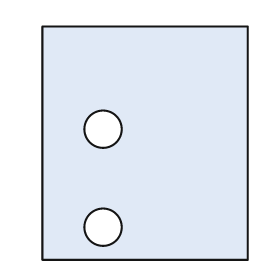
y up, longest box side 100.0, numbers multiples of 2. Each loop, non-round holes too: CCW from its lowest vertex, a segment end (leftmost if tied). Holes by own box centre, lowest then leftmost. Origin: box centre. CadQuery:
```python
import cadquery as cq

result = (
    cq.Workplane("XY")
    .moveTo(-44.0, -50.0)
    .lineTo(44.0, -50.0)
    .lineTo(44.0, 50.0)
    .lineTo(-44.0, 50.0)
    .close()
    .moveTo(-18.0, -36.0)
    .circle(8.0)
    .moveTo(-18.0, 6.0)
    .circle(8.0)
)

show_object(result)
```